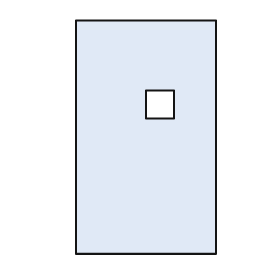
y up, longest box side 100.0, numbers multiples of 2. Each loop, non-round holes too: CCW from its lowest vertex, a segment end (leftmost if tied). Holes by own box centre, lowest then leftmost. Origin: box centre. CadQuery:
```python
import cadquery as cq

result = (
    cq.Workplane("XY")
    .moveTo(-30.0, -50.0)
    .lineTo(30.0, -50.0)
    .lineTo(30.0, 50.0)
    .lineTo(-30.0, 50.0)
    .close()
    .moveTo(0.0, 8.0)
    .lineTo(12.0, 8.0)
    .lineTo(12.0, 20.0)
    .lineTo(0.0, 20.0)
    .close()
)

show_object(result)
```